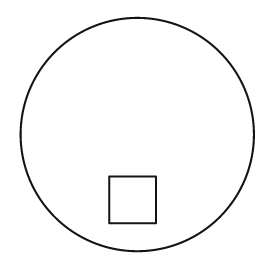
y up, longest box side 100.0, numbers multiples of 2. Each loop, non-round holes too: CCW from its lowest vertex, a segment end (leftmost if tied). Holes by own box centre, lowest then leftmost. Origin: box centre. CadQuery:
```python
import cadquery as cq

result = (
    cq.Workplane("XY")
    .moveTo(0.0, 0.0)
    .circle(50.0)
    .moveTo(-12.0, -38.0)
    .lineTo(8.0, -38.0)
    .lineTo(8.0, -18.0)
    .lineTo(-12.0, -18.0)
    .close()
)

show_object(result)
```